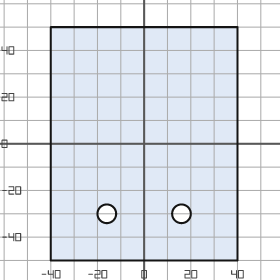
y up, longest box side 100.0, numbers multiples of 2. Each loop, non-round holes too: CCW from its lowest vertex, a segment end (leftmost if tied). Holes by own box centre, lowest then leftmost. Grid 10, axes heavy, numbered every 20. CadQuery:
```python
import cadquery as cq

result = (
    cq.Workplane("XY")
    .moveTo(-40.0, -50.0)
    .lineTo(40.0, -50.0)
    .lineTo(40.0, 50.0)
    .lineTo(-40.0, 50.0)
    .close()
    .moveTo(-16.0, -30.0)
    .circle(4.0)
    .moveTo(16.0, -30.0)
    .circle(4.0)
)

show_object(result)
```